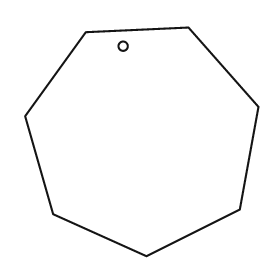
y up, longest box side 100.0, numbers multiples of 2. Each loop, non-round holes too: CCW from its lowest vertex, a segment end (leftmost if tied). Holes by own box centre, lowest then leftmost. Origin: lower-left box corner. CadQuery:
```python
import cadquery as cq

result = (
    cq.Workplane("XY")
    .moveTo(52.0, 0.0)
    .lineTo(92.0, 20.0)
    .lineTo(100.0, 64.0)
    .lineTo(70.0, 98.0)
    .lineTo(26.0, 96.0)
    .lineTo(0.0, 60.0)
    .lineTo(12.0, 18.0)
    .close()
    .moveTo(42.0, 90.0)
    .circle(2.0)
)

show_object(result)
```